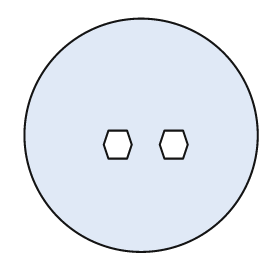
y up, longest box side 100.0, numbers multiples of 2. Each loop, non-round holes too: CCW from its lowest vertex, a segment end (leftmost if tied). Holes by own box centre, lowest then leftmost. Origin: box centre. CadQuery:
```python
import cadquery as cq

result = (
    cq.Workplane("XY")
    .moveTo(0.0, 0.0)
    .circle(50.0)
    .moveTo(-14.0, -10.0)
    .lineTo(-6.0, -10.0)
    .lineTo(-4.0, -4.0)
    .lineTo(-6.0, 2.0)
    .lineTo(-14.0, 2.0)
    .lineTo(-16.0, -4.0)
    .close()
    .moveTo(10.0, -10.0)
    .lineTo(18.0, -10.0)
    .lineTo(20.0, -4.0)
    .lineTo(18.0, 2.0)
    .lineTo(10.0, 2.0)
    .lineTo(8.0, -4.0)
    .close()
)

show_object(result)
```